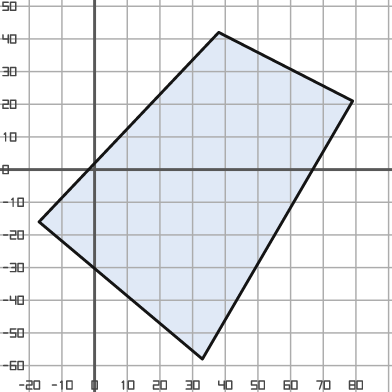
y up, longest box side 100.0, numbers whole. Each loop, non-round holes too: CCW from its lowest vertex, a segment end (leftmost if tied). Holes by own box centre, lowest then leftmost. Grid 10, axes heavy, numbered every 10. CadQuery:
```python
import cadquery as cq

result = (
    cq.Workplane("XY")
    .moveTo(33.0, -58.0)
    .lineTo(79.0, 21.0)
    .lineTo(38.0, 42.0)
    .lineTo(-17.0, -16.0)
    .close()
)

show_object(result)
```